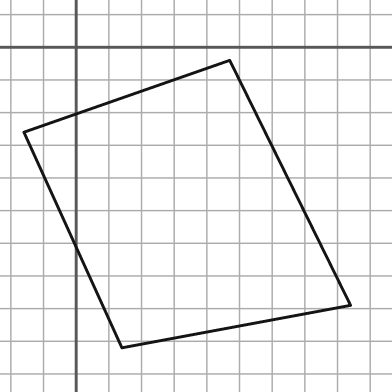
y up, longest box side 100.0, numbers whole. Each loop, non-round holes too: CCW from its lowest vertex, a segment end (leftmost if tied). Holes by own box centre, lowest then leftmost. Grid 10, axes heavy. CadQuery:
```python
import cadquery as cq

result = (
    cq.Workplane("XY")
    .moveTo(14.0, -92.0)
    .lineTo(84.0, -79.0)
    .lineTo(47.0, -4.0)
    .lineTo(-16.0, -26.0)
    .close()
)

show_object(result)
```